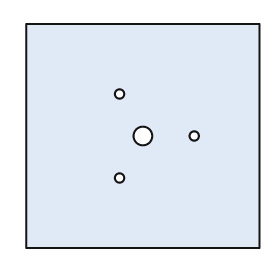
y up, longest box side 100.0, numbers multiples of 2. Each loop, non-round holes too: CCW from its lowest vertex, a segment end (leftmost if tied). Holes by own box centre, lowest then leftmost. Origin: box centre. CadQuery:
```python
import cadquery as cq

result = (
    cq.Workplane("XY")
    .moveTo(-50.0, -48.0)
    .lineTo(50.0, -48.0)
    .lineTo(50.0, 48.0)
    .lineTo(-50.0, 48.0)
    .close()
    .moveTo(-10.0, -18.0)
    .circle(2.0)
    .moveTo(0.0, 0.0)
    .circle(4.0)
    .moveTo(22.0, 0.0)
    .circle(2.0)
    .moveTo(-10.0, 18.0)
    .circle(2.0)
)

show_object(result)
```